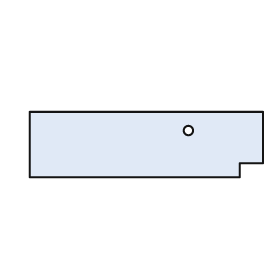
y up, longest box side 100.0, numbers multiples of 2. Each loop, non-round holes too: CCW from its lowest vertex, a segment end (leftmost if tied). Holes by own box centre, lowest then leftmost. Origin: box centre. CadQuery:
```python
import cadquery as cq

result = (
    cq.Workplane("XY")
    .moveTo(-50.0, -14.0)
    .lineTo(40.0, -14.0)
    .lineTo(40.0, -8.0)
    .lineTo(50.0, -8.0)
    .lineTo(50.0, 14.0)
    .lineTo(-50.0, 14.0)
    .close()
    .moveTo(18.0, 6.0)
    .circle(2.0)
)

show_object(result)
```